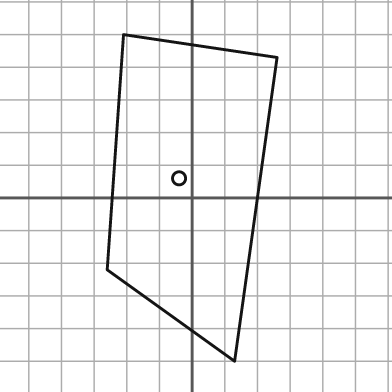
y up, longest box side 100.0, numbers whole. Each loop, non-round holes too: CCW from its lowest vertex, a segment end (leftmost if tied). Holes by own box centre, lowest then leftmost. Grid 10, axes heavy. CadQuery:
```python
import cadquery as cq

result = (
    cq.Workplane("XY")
    .moveTo(13.0, -50.0)
    .lineTo(26.0, 43.0)
    .lineTo(-21.0, 50.0)
    .lineTo(-26.0, -22.0)
    .close()
    .moveTo(-4.0, 6.0)
    .circle(2.0)
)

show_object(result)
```